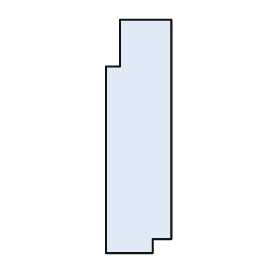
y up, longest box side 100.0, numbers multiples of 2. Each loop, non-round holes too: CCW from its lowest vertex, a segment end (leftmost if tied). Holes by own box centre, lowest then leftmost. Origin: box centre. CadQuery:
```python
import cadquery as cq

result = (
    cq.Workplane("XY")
    .moveTo(-14.0, -50.0)
    .lineTo(6.0, -50.0)
    .lineTo(6.0, -44.0)
    .lineTo(14.0, -44.0)
    .lineTo(14.0, 50.0)
    .lineTo(-8.0, 50.0)
    .lineTo(-8.0, 30.0)
    .lineTo(-14.0, 30.0)
    .close()
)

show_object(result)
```